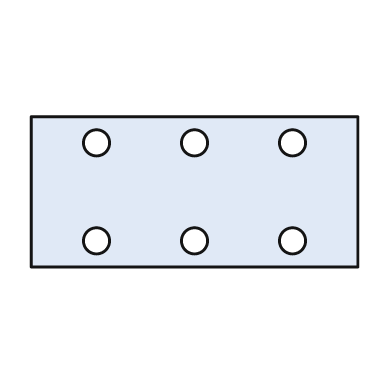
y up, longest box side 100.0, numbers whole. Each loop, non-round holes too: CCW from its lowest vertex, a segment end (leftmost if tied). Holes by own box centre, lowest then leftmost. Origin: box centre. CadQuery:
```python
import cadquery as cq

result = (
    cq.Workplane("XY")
    .moveTo(-50.0, -23.0)
    .lineTo(50.0, -23.0)
    .lineTo(50.0, 23.0)
    .lineTo(-50.0, 23.0)
    .close()
    .moveTo(-30.0, -15.0)
    .circle(4.0)
    .moveTo(0.0, -15.0)
    .circle(4.0)
    .moveTo(30.0, -15.0)
    .circle(4.0)
    .moveTo(-30.0, 15.0)
    .circle(4.0)
    .moveTo(0.0, 15.0)
    .circle(4.0)
    .moveTo(30.0, 15.0)
    .circle(4.0)
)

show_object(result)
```